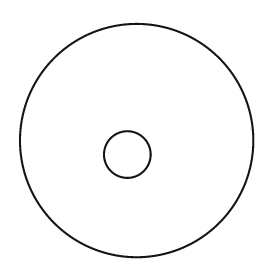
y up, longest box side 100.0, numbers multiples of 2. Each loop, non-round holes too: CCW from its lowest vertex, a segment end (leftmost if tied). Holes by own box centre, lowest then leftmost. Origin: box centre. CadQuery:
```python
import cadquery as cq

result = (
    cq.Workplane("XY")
    .moveTo(0.0, 0.0)
    .circle(50.0)
    .moveTo(-4.0, -6.0)
    .circle(10.0)
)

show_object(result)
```